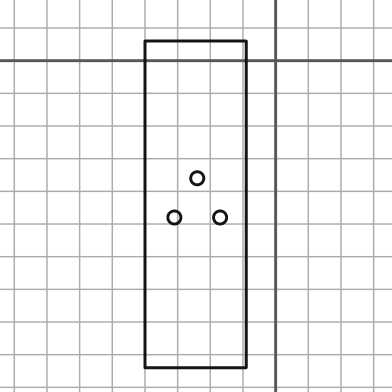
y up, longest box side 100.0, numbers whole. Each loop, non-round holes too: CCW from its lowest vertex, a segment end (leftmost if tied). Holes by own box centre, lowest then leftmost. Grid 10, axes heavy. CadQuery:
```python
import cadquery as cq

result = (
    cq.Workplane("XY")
    .moveTo(-40.0, -94.0)
    .lineTo(-9.0, -94.0)
    .lineTo(-9.0, 6.0)
    .lineTo(-40.0, 6.0)
    .close()
    .moveTo(-31.0, -48.0)
    .circle(2.0)
    .moveTo(-17.0, -48.0)
    .circle(2.0)
    .moveTo(-24.0, -36.0)
    .circle(2.0)
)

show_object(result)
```